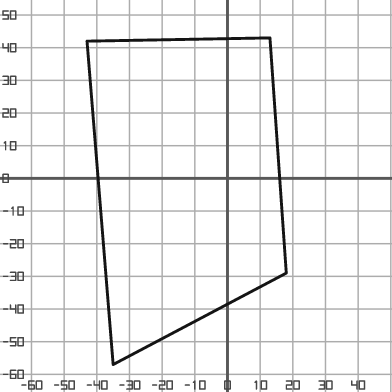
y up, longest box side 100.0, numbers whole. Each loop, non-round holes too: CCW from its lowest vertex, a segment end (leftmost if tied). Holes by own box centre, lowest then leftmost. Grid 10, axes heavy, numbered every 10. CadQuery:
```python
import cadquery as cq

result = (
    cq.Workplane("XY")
    .moveTo(-35.0, -57.0)
    .lineTo(18.0, -29.0)
    .lineTo(13.0, 43.0)
    .lineTo(-43.0, 42.0)
    .close()
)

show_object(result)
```